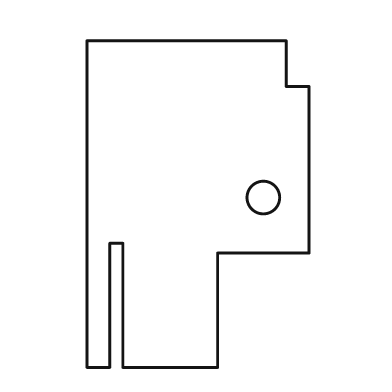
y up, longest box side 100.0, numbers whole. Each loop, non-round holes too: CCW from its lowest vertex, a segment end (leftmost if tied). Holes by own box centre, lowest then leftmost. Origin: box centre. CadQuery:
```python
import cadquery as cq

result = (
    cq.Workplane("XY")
    .moveTo(-34.0, -50.0)
    .lineTo(-27.0, -50.0)
    .lineTo(-27.0, -12.0)
    .lineTo(-23.0, -12.0)
    .lineTo(-23.0, -50.0)
    .lineTo(6.0, -50.0)
    .lineTo(6.0, -15.0)
    .lineTo(34.0, -15.0)
    .lineTo(34.0, 36.0)
    .lineTo(27.0, 36.0)
    .lineTo(27.0, 50.0)
    .lineTo(-34.0, 50.0)
    .close()
    .moveTo(20.0, 2.0)
    .circle(5.0)
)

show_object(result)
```